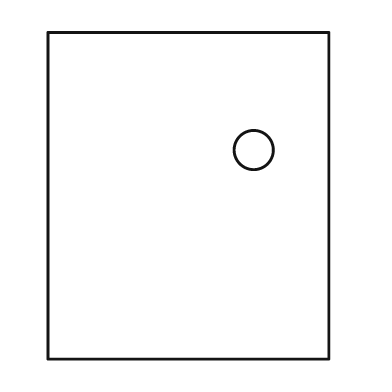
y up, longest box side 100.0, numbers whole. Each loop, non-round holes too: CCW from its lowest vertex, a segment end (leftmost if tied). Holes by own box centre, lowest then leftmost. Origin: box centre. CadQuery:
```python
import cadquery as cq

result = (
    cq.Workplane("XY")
    .moveTo(-43.0, -50.0)
    .lineTo(43.0, -50.0)
    .lineTo(43.0, 50.0)
    .lineTo(-43.0, 50.0)
    .close()
    .moveTo(20.0, 14.0)
    .circle(6.0)
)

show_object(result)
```